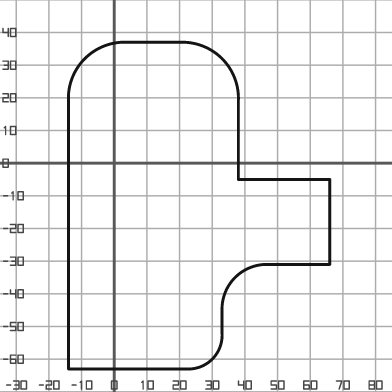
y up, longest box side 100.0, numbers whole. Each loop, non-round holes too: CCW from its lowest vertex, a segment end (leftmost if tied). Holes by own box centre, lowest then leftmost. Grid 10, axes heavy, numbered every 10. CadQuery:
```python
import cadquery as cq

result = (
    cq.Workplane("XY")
    .moveTo(-14.0, -63.0)
    .lineTo(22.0, -63.0)
    .threePointArc((30.0, -60.0), (33.0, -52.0))
    .lineTo(33.0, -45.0)
    .threePointArc((37.0, -35.0), (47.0, -31.0))
    .lineTo(66.0, -31.0)
    .lineTo(66.0, -5.0)
    .lineTo(38.0, -5.0)
    .lineTo(38.0, 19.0)
    .threePointArc((33.0, 32.0), (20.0, 37.0))
    .lineTo(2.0, 37.0)
    .threePointArc((-9.0, 32.0), (-14.0, 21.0))
    .close()
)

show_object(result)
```